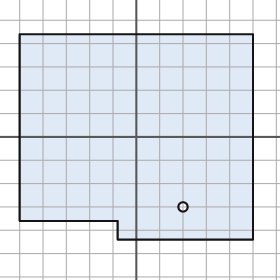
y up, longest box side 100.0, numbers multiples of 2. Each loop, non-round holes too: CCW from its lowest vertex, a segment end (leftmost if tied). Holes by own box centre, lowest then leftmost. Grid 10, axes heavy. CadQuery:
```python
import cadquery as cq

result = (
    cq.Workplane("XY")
    .moveTo(-8.0, -44.0)
    .lineTo(50.0, -44.0)
    .lineTo(50.0, 44.0)
    .lineTo(-50.0, 44.0)
    .lineTo(-50.0, -36.0)
    .lineTo(-8.0, -36.0)
    .close()
    .moveTo(20.0, -30.0)
    .circle(2.0)
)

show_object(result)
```